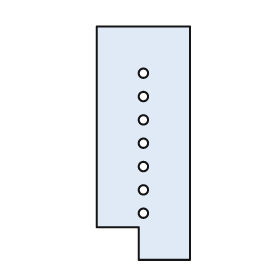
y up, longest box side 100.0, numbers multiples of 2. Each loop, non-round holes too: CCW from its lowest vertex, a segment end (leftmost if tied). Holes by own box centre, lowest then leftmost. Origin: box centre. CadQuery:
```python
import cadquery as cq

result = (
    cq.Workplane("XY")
    .moveTo(-2.0, -50.0)
    .lineTo(20.0, -50.0)
    .lineTo(20.0, 50.0)
    .lineTo(-20.0, 50.0)
    .lineTo(-20.0, -36.0)
    .lineTo(-2.0, -36.0)
    .close()
    .moveTo(0.0, -30.0)
    .circle(2.0)
    .moveTo(0.0, -20.0)
    .circle(2.0)
    .moveTo(0.0, -10.0)
    .circle(2.0)
    .moveTo(0.0, 0.0)
    .circle(2.0)
    .moveTo(0.0, 10.0)
    .circle(2.0)
    .moveTo(0.0, 20.0)
    .circle(2.0)
    .moveTo(0.0, 30.0)
    .circle(2.0)
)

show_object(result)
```